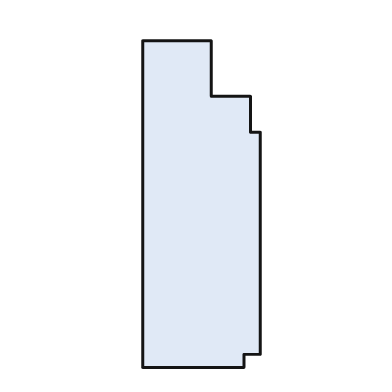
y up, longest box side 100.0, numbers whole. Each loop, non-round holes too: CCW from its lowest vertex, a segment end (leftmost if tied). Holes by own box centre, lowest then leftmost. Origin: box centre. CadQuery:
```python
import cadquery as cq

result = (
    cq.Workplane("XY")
    .moveTo(-18.0, -50.0)
    .lineTo(13.0, -50.0)
    .lineTo(13.0, -46.0)
    .lineTo(18.0, -46.0)
    .lineTo(18.0, 22.0)
    .lineTo(15.0, 22.0)
    .lineTo(15.0, 33.0)
    .lineTo(3.0, 33.0)
    .lineTo(3.0, 50.0)
    .lineTo(-18.0, 50.0)
    .close()
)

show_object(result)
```